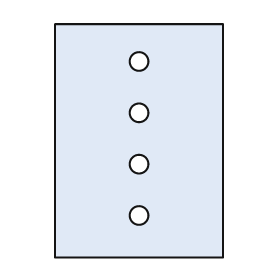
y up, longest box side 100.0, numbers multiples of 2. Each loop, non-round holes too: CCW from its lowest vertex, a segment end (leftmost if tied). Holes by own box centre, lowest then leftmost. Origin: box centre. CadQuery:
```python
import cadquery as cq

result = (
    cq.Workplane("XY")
    .moveTo(-36.0, -50.0)
    .lineTo(36.0, -50.0)
    .lineTo(36.0, 50.0)
    .lineTo(-36.0, 50.0)
    .close()
    .moveTo(0.0, -32.0)
    .circle(4.0)
    .moveTo(0.0, -10.0)
    .circle(4.0)
    .moveTo(0.0, 12.0)
    .circle(4.0)
    .moveTo(0.0, 34.0)
    .circle(4.0)
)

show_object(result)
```